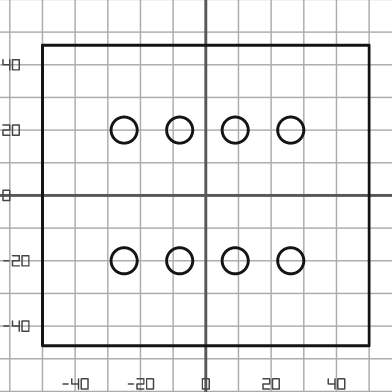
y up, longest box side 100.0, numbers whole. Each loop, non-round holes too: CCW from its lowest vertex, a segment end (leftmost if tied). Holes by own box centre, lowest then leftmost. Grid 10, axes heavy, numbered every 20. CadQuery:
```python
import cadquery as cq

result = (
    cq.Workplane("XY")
    .moveTo(-50.0, -46.0)
    .lineTo(50.0, -46.0)
    .lineTo(50.0, 46.0)
    .lineTo(-50.0, 46.0)
    .close()
    .moveTo(-25.0, -20.0)
    .circle(4.0)
    .moveTo(-8.0, -20.0)
    .circle(4.0)
    .moveTo(9.0, -20.0)
    .circle(4.0)
    .moveTo(26.0, -20.0)
    .circle(4.0)
    .moveTo(-25.0, 20.0)
    .circle(4.0)
    .moveTo(-8.0, 20.0)
    .circle(4.0)
    .moveTo(9.0, 20.0)
    .circle(4.0)
    .moveTo(26.0, 20.0)
    .circle(4.0)
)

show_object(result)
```